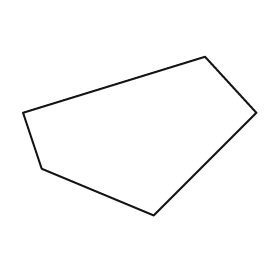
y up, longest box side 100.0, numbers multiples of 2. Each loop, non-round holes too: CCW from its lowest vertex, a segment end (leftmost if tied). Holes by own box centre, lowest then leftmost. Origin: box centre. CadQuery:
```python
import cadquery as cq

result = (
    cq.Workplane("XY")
    .moveTo(6.0, -34.0)
    .lineTo(50.0, 10.0)
    .lineTo(28.0, 34.0)
    .lineTo(-50.0, 10.0)
    .lineTo(-42.0, -14.0)
    .close()
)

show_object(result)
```